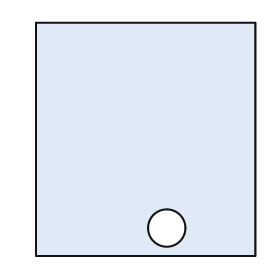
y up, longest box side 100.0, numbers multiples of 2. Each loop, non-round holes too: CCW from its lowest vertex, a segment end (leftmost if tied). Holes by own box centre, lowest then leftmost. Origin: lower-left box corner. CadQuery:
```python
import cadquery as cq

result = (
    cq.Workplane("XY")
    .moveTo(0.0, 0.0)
    .lineTo(94.0, 0.0)
    .lineTo(94.0, 100.0)
    .lineTo(0.0, 100.0)
    .close()
    .moveTo(56.0, 12.0)
    .circle(8.0)
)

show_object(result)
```